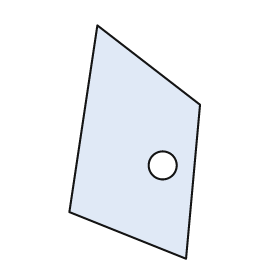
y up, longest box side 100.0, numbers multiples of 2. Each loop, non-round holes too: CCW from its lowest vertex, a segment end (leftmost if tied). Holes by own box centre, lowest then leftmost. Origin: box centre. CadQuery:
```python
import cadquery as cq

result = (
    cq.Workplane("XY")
    .moveTo(22.0, -50.0)
    .lineTo(28.0, 16.0)
    .lineTo(-16.0, 50.0)
    .lineTo(-28.0, -30.0)
    .close()
    .moveTo(12.0, -10.0)
    .circle(6.0)
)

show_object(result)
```